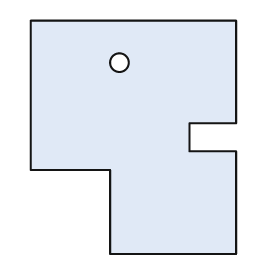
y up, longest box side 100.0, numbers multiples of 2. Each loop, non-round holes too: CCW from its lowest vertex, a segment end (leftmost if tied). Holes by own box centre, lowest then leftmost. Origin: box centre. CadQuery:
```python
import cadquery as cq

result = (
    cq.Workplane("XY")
    .moveTo(-10.0, -50.0)
    .lineTo(44.0, -50.0)
    .lineTo(44.0, -6.0)
    .lineTo(24.0, -6.0)
    .lineTo(24.0, 6.0)
    .lineTo(44.0, 6.0)
    .lineTo(44.0, 50.0)
    .lineTo(-44.0, 50.0)
    .lineTo(-44.0, -14.0)
    .lineTo(-10.0, -14.0)
    .close()
    .moveTo(-6.0, 32.0)
    .circle(4.0)
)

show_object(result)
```